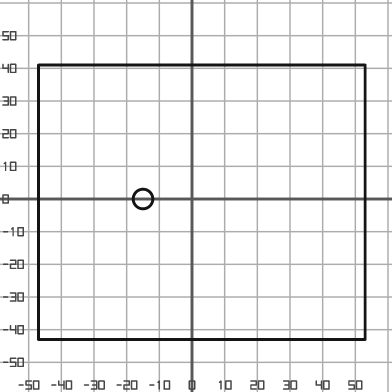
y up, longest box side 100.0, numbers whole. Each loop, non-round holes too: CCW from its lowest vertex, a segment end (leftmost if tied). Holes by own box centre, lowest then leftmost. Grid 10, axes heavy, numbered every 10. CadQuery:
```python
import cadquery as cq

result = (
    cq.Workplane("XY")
    .moveTo(-47.0, -43.0)
    .lineTo(53.0, -43.0)
    .lineTo(53.0, 41.0)
    .lineTo(-47.0, 41.0)
    .close()
    .moveTo(-15.0, 0.0)
    .circle(3.0)
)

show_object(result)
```